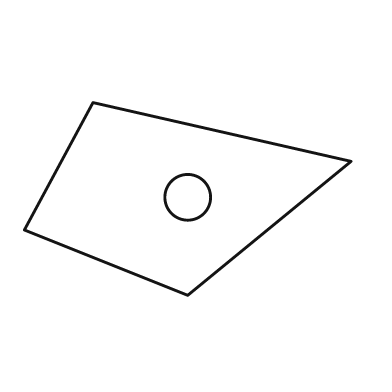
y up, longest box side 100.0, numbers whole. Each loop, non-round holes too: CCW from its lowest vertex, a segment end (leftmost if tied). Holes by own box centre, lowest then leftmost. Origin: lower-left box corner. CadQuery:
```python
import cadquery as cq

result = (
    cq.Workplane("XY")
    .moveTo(50.0, 0.0)
    .lineTo(100.0, 41.0)
    .lineTo(21.0, 59.0)
    .lineTo(0.0, 20.0)
    .close()
    .moveTo(50.0, 30.0)
    .circle(7.0)
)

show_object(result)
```